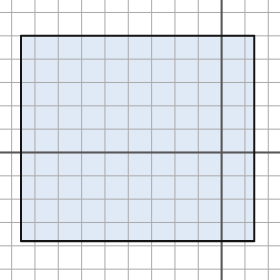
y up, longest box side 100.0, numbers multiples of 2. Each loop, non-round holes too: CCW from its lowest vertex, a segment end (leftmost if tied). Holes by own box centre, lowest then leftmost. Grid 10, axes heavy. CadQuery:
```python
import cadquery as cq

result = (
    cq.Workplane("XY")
    .moveTo(-86.0, -38.0)
    .lineTo(14.0, -38.0)
    .lineTo(14.0, 50.0)
    .lineTo(-86.0, 50.0)
    .close()
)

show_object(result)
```